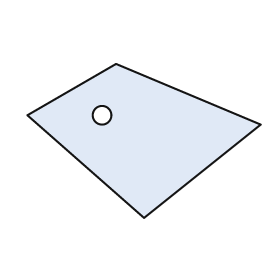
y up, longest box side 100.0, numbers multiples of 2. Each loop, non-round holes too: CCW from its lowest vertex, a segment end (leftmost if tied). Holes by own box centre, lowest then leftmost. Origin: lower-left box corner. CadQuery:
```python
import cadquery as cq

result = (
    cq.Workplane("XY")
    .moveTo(50.0, 0.0)
    .lineTo(100.0, 40.0)
    .lineTo(38.0, 66.0)
    .lineTo(0.0, 44.0)
    .close()
    .moveTo(32.0, 44.0)
    .circle(4.0)
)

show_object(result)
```